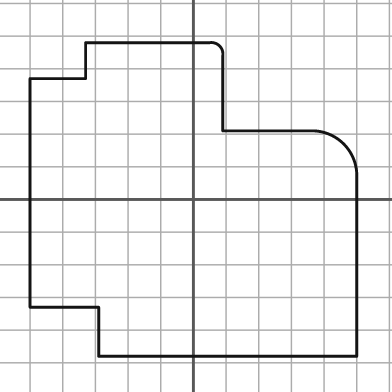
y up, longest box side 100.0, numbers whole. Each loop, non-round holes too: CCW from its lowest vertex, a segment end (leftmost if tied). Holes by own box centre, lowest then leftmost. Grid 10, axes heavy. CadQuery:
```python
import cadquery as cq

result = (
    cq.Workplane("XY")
    .moveTo(-29.0, -48.0)
    .lineTo(50.0, -48.0)
    .lineTo(50.0, 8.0)
    .threePointArc((46.0, 17.0), (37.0, 21.0))
    .lineTo(9.0, 21.0)
    .lineTo(9.0, 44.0)
    .threePointArc((8.0, 47.0), (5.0, 48.0))
    .lineTo(-33.0, 48.0)
    .lineTo(-33.0, 37.0)
    .lineTo(-50.0, 37.0)
    .lineTo(-50.0, -33.0)
    .lineTo(-29.0, -33.0)
    .close()
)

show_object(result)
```